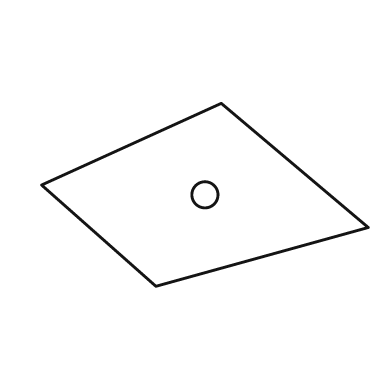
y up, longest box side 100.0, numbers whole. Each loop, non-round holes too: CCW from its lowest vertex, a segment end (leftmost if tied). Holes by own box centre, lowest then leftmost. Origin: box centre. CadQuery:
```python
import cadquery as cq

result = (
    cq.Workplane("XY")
    .moveTo(-15.0, -28.0)
    .lineTo(50.0, -10.0)
    .lineTo(5.0, 28.0)
    .lineTo(-50.0, 3.0)
    .close()
    .moveTo(0.0, 0.0)
    .circle(4.0)
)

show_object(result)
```